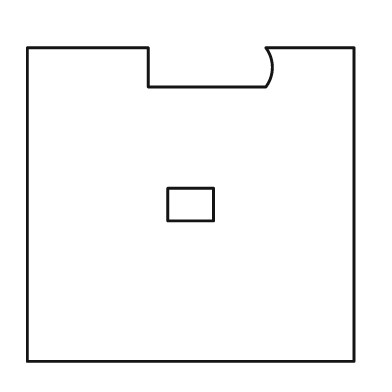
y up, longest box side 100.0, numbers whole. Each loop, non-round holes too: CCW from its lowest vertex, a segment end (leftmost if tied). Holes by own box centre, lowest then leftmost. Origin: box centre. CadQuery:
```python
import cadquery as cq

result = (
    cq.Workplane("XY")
    .moveTo(-50.0, -48.0)
    .lineTo(50.0, -48.0)
    .lineTo(50.0, 48.0)
    .lineTo(23.0, 48.0)
    .threePointArc((25.0, 42.0), (23.0, 36.0))
    .lineTo(-13.0, 36.0)
    .lineTo(-13.0, 48.0)
    .lineTo(-50.0, 48.0)
    .close()
    .moveTo(-7.0, -5.0)
    .lineTo(7.0, -5.0)
    .lineTo(7.0, 5.0)
    .lineTo(-7.0, 5.0)
    .close()
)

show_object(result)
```